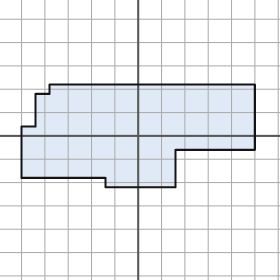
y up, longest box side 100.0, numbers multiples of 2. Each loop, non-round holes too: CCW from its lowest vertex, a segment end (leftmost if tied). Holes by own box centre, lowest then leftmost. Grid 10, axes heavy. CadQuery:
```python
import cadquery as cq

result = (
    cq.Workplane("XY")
    .moveTo(-14.0, -22.0)
    .lineTo(16.0, -22.0)
    .lineTo(16.0, -6.0)
    .lineTo(50.0, -6.0)
    .lineTo(50.0, 22.0)
    .lineTo(-38.0, 22.0)
    .lineTo(-38.0, 18.0)
    .lineTo(-44.0, 18.0)
    .lineTo(-44.0, 4.0)
    .lineTo(-50.0, 4.0)
    .lineTo(-50.0, -18.0)
    .lineTo(-14.0, -18.0)
    .close()
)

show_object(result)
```